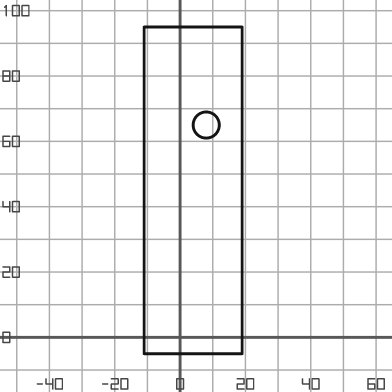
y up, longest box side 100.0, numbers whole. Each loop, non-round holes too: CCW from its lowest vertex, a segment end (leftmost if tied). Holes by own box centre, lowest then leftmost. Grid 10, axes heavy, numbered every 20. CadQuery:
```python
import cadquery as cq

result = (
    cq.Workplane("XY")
    .moveTo(-11.0, -5.0)
    .lineTo(19.0, -5.0)
    .lineTo(19.0, 95.0)
    .lineTo(-11.0, 95.0)
    .close()
    .moveTo(8.0, 65.0)
    .circle(4.0)
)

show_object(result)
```